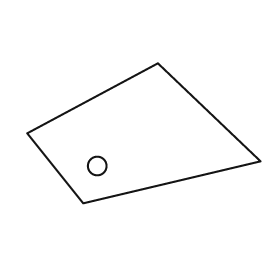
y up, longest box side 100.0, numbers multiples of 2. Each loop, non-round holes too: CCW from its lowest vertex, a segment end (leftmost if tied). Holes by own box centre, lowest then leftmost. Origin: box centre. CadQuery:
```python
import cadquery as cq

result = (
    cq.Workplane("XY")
    .moveTo(-26.0, -30.0)
    .lineTo(50.0, -12.0)
    .lineTo(6.0, 30.0)
    .lineTo(-50.0, 0.0)
    .close()
    .moveTo(-20.0, -14.0)
    .circle(4.0)
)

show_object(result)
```